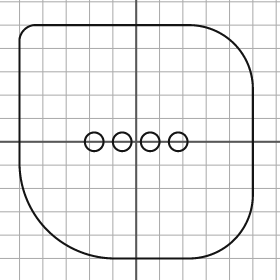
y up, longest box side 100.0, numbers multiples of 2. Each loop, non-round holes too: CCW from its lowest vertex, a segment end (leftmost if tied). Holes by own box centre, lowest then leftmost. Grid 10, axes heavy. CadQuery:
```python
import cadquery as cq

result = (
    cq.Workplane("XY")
    .moveTo(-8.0, -50.0)
    .lineTo(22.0, -50.0)
    .threePointArc((42.0, -42.0), (50.0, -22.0))
    .lineTo(50.0, 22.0)
    .threePointArc((42.0, 42.0), (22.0, 50.0))
    .lineTo(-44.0, 50.0)
    .threePointArc((-48.0, 48.0), (-50.0, 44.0))
    .lineTo(-50.0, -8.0)
    .threePointArc((-38.0, -38.0), (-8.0, -50.0))
    .close()
    .moveTo(-18.0, 0.0)
    .circle(4.0)
    .moveTo(-6.0, 0.0)
    .circle(4.0)
    .moveTo(6.0, 0.0)
    .circle(4.0)
    .moveTo(18.0, 0.0)
    .circle(4.0)
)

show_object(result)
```